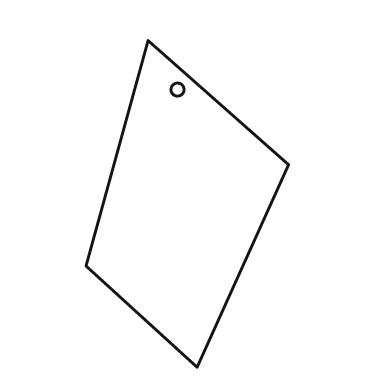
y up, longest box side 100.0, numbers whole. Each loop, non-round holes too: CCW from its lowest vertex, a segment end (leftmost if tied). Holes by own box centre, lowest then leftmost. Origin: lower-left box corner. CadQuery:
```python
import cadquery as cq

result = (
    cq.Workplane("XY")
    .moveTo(34.0, 0.0)
    .lineTo(62.0, 62.0)
    .lineTo(19.0, 100.0)
    .lineTo(0.0, 31.0)
    .close()
    .moveTo(28.0, 85.0)
    .circle(2.0)
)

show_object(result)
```